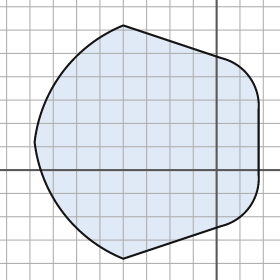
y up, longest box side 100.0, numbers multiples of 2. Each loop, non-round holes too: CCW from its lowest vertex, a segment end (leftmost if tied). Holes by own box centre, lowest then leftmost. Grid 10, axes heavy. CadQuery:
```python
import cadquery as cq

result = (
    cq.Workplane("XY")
    .moveTo(-40.0, -38.0)
    .lineTo(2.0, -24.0)
    .threePointArc((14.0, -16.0), (18.0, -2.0))
    .lineTo(18.0, 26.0)
    .threePointArc((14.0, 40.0), (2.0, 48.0))
    .lineTo(-40.0, 62.0)
    .threePointArc((-66.0, 42.0), (-78.0, 12.0))
    .threePointArc((-66.0, -18.0), (-40.0, -38.0))
    .close()
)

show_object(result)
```